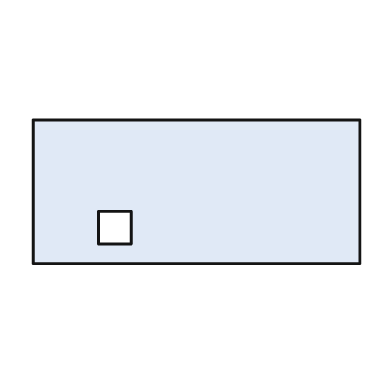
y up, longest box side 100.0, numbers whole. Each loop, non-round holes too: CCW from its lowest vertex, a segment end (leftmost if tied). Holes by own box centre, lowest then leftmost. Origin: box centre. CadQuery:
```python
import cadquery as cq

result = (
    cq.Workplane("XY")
    .moveTo(-50.0, -22.0)
    .lineTo(50.0, -22.0)
    .lineTo(50.0, 22.0)
    .lineTo(-50.0, 22.0)
    .close()
    .moveTo(-30.0, -16.0)
    .lineTo(-20.0, -16.0)
    .lineTo(-20.0, -6.0)
    .lineTo(-30.0, -6.0)
    .close()
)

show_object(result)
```